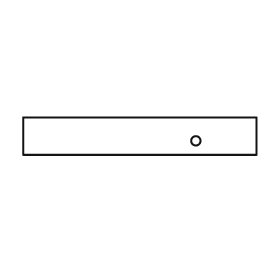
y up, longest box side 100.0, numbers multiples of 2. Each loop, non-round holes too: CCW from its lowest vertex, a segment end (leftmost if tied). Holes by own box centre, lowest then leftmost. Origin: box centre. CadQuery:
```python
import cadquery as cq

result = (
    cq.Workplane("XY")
    .moveTo(-50.0, -8.0)
    .lineTo(50.0, -8.0)
    .lineTo(50.0, 8.0)
    .lineTo(-50.0, 8.0)
    .close()
    .moveTo(24.0, -2.0)
    .circle(2.0)
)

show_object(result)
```